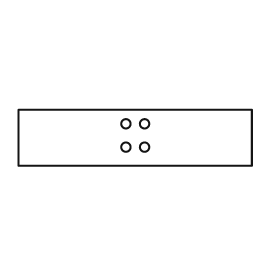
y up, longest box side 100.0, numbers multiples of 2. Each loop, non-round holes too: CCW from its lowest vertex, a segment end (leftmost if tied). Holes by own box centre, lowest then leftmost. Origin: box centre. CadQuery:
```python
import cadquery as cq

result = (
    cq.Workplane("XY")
    .moveTo(-50.0, -12.0)
    .lineTo(50.0, -12.0)
    .lineTo(50.0, 12.0)
    .lineTo(-50.0, 12.0)
    .close()
    .moveTo(-4.0, -4.0)
    .circle(2.0)
    .moveTo(4.0, -4.0)
    .circle(2.0)
    .moveTo(-4.0, 6.0)
    .circle(2.0)
    .moveTo(4.0, 6.0)
    .circle(2.0)
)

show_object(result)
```